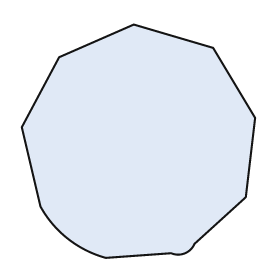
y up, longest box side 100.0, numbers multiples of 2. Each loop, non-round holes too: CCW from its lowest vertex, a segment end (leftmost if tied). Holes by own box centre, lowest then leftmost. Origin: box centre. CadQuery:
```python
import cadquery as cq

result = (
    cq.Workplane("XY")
    .moveTo(-14.0, -50.0)
    .lineTo(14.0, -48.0)
    .threePointArc((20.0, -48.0), (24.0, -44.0))
    .lineTo(46.0, -24.0)
    .lineTo(50.0, 10.0)
    .lineTo(32.0, 40.0)
    .lineTo(-2.0, 50.0)
    .lineTo(-34.0, 36.0)
    .lineTo(-50.0, 6.0)
    .lineTo(-42.0, -28.0)
    .threePointArc((-30.0, -42.0), (-14.0, -50.0))
    .close()
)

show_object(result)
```